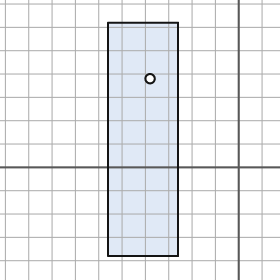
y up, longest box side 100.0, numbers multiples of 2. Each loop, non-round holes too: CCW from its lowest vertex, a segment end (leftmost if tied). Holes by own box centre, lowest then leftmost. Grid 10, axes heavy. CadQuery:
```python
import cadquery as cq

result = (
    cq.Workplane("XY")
    .moveTo(-56.0, -38.0)
    .lineTo(-26.0, -38.0)
    .lineTo(-26.0, 62.0)
    .lineTo(-56.0, 62.0)
    .close()
    .moveTo(-38.0, 38.0)
    .circle(2.0)
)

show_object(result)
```